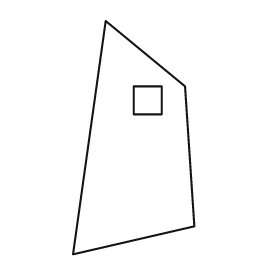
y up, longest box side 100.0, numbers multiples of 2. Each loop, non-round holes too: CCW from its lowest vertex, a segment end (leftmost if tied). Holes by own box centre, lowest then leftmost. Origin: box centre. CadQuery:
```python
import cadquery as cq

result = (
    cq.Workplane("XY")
    .moveTo(-26.0, -50.0)
    .lineTo(26.0, -38.0)
    .lineTo(22.0, 22.0)
    .lineTo(-12.0, 50.0)
    .close()
    .moveTo(0.0, 10.0)
    .lineTo(12.0, 10.0)
    .lineTo(12.0, 22.0)
    .lineTo(0.0, 22.0)
    .close()
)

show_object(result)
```